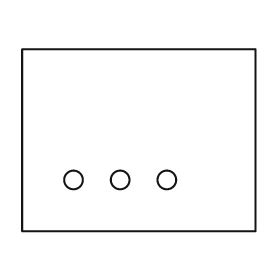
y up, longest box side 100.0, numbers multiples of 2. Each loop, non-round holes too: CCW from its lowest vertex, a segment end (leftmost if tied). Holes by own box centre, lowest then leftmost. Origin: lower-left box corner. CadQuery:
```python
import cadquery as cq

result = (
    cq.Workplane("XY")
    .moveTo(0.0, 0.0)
    .lineTo(100.0, 0.0)
    .lineTo(100.0, 78.0)
    .lineTo(0.0, 78.0)
    .close()
    .moveTo(22.0, 22.0)
    .circle(4.0)
    .moveTo(42.0, 22.0)
    .circle(4.0)
    .moveTo(62.0, 22.0)
    .circle(4.0)
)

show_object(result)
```